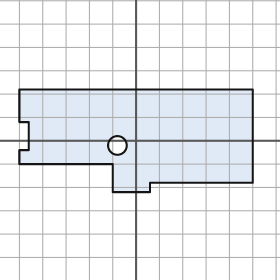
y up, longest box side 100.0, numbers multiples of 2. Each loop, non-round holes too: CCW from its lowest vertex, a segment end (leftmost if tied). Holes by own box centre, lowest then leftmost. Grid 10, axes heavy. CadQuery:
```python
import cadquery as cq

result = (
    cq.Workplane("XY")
    .moveTo(-10.0, -22.0)
    .lineTo(6.0, -22.0)
    .lineTo(6.0, -18.0)
    .lineTo(50.0, -18.0)
    .lineTo(50.0, 22.0)
    .lineTo(-50.0, 22.0)
    .lineTo(-50.0, 8.0)
    .lineTo(-46.0, 8.0)
    .lineTo(-46.0, -4.0)
    .lineTo(-50.0, -4.0)
    .lineTo(-50.0, -10.0)
    .lineTo(-10.0, -10.0)
    .close()
    .moveTo(-8.0, -2.0)
    .circle(4.0)
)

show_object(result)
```